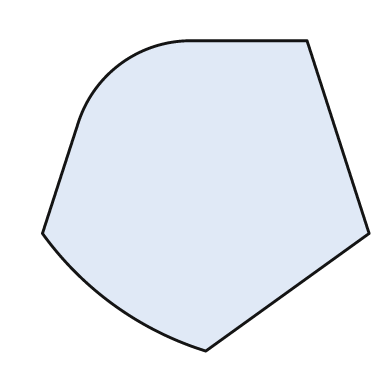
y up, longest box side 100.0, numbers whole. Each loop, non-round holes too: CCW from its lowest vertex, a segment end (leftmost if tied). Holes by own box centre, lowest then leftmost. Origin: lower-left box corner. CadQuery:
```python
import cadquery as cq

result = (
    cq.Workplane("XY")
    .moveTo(50.0, 0.0)
    .lineTo(100.0, 36.0)
    .lineTo(81.0, 95.0)
    .lineTo(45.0, 95.0)
    .threePointArc((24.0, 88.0), (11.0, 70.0))
    .lineTo(0.0, 36.0)
    .threePointArc((22.0, 14.0), (50.0, 0.0))
    .close()
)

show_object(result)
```